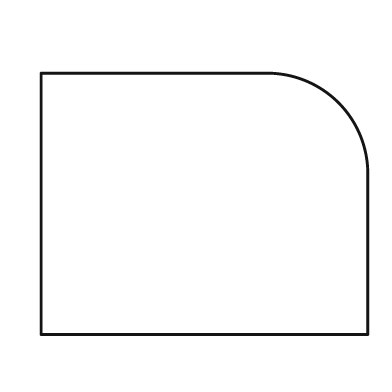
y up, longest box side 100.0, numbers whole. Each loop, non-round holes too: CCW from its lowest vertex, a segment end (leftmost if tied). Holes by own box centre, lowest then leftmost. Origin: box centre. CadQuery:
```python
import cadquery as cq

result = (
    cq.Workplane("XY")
    .moveTo(-50.0, -40.0)
    .lineTo(50.0, -40.0)
    .lineTo(50.0, 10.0)
    .threePointArc((41.0, 31.0), (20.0, 40.0))
    .lineTo(-50.0, 40.0)
    .close()
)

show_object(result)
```